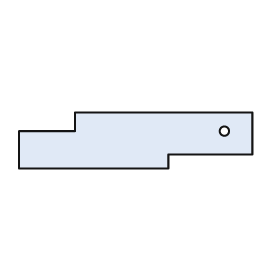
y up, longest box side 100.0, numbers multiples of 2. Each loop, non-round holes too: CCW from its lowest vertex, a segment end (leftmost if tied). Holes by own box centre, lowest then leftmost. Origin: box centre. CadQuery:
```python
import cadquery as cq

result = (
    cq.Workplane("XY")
    .moveTo(-50.0, -12.0)
    .lineTo(14.0, -12.0)
    .lineTo(14.0, -6.0)
    .lineTo(50.0, -6.0)
    .lineTo(50.0, 12.0)
    .lineTo(-26.0, 12.0)
    .lineTo(-26.0, 4.0)
    .lineTo(-50.0, 4.0)
    .close()
    .moveTo(38.0, 4.0)
    .circle(2.0)
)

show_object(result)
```